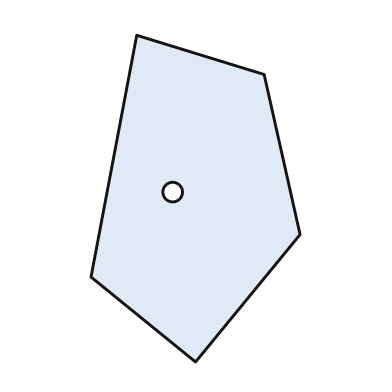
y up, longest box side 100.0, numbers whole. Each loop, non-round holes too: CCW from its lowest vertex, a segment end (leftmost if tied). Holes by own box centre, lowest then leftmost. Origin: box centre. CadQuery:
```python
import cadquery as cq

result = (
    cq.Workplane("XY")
    .moveTo(0.0, -50.0)
    .lineTo(32.0, -11.0)
    .lineTo(21.0, 38.0)
    .lineTo(-18.0, 50.0)
    .lineTo(-32.0, -24.0)
    .close()
    .moveTo(-7.0, 2.0)
    .circle(3.0)
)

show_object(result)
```